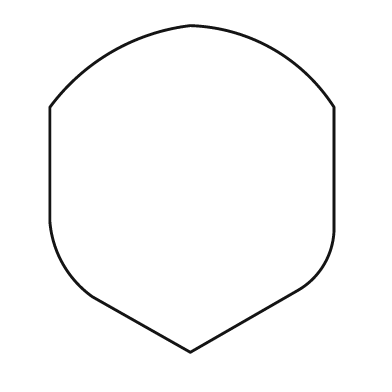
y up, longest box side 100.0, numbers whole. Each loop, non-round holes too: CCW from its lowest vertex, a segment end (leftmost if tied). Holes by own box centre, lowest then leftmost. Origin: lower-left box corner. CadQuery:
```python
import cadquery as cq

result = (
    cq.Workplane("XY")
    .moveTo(43.0, 0.0)
    .lineTo(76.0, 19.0)
    .threePointArc((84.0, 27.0), (87.0, 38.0))
    .lineTo(87.0, 75.0)
    .threePointArc((68.0, 93.0), (43.0, 100.0))
    .threePointArc((19.0, 92.0), (0.0, 75.0))
    .lineTo(0.0, 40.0)
    .threePointArc((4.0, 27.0), (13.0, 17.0))
    .close()
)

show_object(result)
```